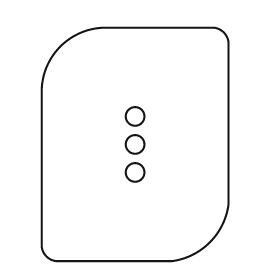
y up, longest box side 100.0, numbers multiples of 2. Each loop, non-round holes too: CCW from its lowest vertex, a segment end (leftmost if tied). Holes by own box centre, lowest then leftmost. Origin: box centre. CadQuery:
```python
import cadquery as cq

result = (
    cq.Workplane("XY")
    .moveTo(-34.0, -50.0)
    .lineTo(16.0, -50.0)
    .threePointArc((32.0, -42.0), (40.0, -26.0))
    .lineTo(40.0, 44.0)
    .threePointArc((38.0, 48.0), (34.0, 50.0))
    .lineTo(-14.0, 50.0)
    .threePointArc((-32.0, 42.0), (-40.0, 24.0))
    .lineTo(-40.0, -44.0)
    .threePointArc((-38.0, -48.0), (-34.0, -50.0))
    .close()
    .moveTo(0.0, -12.0)
    .circle(4.0)
    .moveTo(0.0, 0.0)
    .circle(4.0)
    .moveTo(0.0, 12.0)
    .circle(4.0)
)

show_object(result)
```